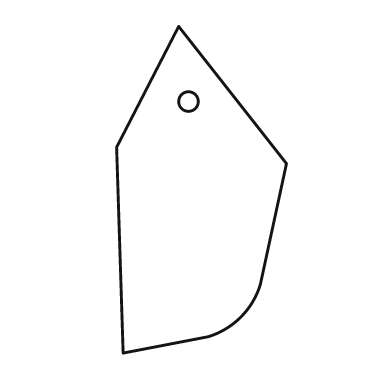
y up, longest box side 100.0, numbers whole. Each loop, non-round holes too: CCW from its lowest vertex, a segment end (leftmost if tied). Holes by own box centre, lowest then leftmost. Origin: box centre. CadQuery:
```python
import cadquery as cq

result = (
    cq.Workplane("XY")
    .moveTo(-24.0, -50.0)
    .lineTo(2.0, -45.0)
    .threePointArc((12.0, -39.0), (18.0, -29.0))
    .lineTo(26.0, 8.0)
    .lineTo(-7.0, 50.0)
    .lineTo(-26.0, 13.0)
    .close()
    .moveTo(-4.0, 27.0)
    .circle(3.0)
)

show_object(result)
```